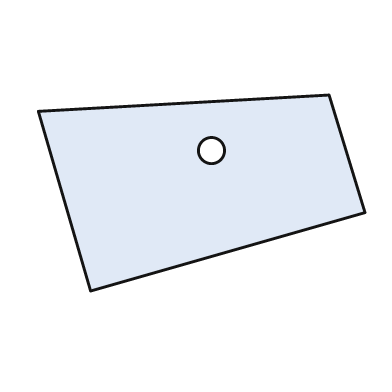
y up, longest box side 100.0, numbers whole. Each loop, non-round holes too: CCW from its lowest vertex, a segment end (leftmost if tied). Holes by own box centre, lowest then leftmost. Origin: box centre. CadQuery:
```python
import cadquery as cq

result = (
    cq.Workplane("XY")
    .moveTo(-34.0, -30.0)
    .lineTo(50.0, -6.0)
    .lineTo(39.0, 30.0)
    .lineTo(-50.0, 25.0)
    .close()
    .moveTo(3.0, 13.0)
    .circle(4.0)
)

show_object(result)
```